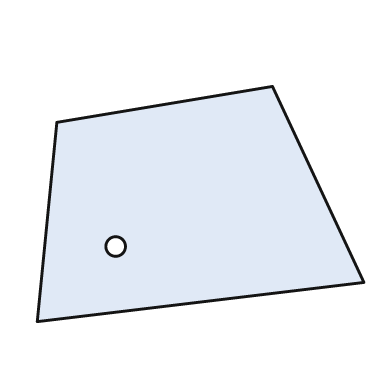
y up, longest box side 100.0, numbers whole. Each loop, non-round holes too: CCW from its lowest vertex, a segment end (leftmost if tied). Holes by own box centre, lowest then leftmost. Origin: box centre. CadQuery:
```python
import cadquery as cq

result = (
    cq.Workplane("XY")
    .moveTo(-50.0, -36.0)
    .lineTo(50.0, -24.0)
    .lineTo(22.0, 36.0)
    .lineTo(-44.0, 25.0)
    .close()
    .moveTo(-26.0, -13.0)
    .circle(3.0)
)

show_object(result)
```